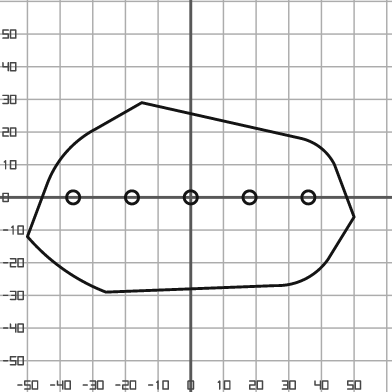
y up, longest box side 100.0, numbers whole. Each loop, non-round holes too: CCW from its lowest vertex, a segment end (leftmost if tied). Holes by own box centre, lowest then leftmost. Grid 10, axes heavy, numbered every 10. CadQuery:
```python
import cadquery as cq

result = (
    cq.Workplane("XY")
    .moveTo(-26.0, -29.0)
    .lineTo(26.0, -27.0)
    .threePointArc((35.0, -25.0), (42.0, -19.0))
    .lineTo(50.0, -6.0)
    .lineTo(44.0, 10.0)
    .threePointArc((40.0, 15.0), (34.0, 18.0))
    .lineTo(-15.0, 29.0)
    .lineTo(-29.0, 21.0)
    .threePointArc((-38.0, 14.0), (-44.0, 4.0))
    .lineTo(-50.0, -12.0)
    .threePointArc((-39.0, -22.0), (-26.0, -29.0))
    .close()
    .moveTo(-36.0, 0.0)
    .circle(2.0)
    .moveTo(-18.0, 0.0)
    .circle(2.0)
    .moveTo(0.0, 0.0)
    .circle(2.0)
    .moveTo(18.0, 0.0)
    .circle(2.0)
    .moveTo(36.0, 0.0)
    .circle(2.0)
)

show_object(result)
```